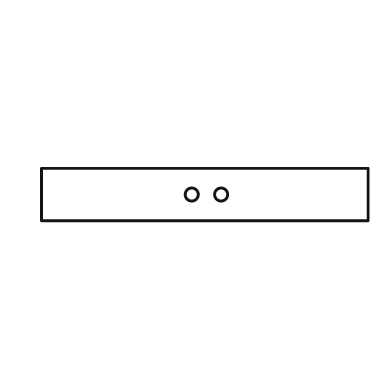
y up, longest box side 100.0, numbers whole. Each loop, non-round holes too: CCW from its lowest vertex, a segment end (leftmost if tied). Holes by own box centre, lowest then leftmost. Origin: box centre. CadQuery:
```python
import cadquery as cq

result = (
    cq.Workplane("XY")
    .moveTo(-50.0, -8.0)
    .lineTo(50.0, -8.0)
    .lineTo(50.0, 8.0)
    .lineTo(-50.0, 8.0)
    .close()
    .moveTo(-4.0, 0.0)
    .circle(2.0)
    .moveTo(5.0, 0.0)
    .circle(2.0)
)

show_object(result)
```